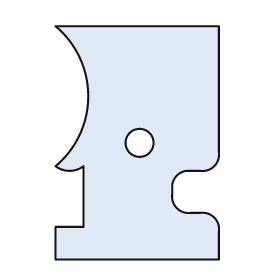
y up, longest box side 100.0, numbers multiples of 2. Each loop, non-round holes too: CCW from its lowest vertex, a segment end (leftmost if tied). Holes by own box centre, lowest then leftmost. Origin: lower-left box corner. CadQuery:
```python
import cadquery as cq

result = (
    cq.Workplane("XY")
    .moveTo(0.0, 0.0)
    .lineTo(70.0, 0.0)
    .lineTo(70.0, 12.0)
    .threePointArc((68.0, 18.0), (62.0, 20.0))
    .lineTo(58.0, 20.0)
    .threePointArc((52.0, 22.0), (50.0, 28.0))
    .lineTo(50.0, 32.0)
    .threePointArc((52.0, 36.0), (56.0, 38.0))
    .lineTo(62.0, 38.0)
    .threePointArc((68.0, 40.0), (70.0, 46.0))
    .lineTo(70.0, 100.0)
    .lineTo(0.0, 100.0)
    .threePointArc((14.0, 70.0), (0.0, 40.0))
    .threePointArc((6.0, 38.0), (12.0, 40.0))
    .lineTo(12.0, 14.0)
    .lineTo(0.0, 14.0)
    .close()
    .moveTo(36.0, 50.0)
    .circle(6.0)
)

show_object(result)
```